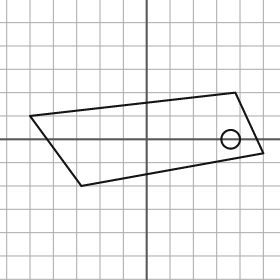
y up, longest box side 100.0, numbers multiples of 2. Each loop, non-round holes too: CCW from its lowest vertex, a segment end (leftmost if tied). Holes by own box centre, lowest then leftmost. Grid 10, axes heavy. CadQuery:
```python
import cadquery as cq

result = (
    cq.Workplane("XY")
    .moveTo(-28.0, -20.0)
    .lineTo(50.0, -6.0)
    .lineTo(38.0, 20.0)
    .lineTo(-50.0, 10.0)
    .close()
    .moveTo(36.0, 0.0)
    .circle(4.0)
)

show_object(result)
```